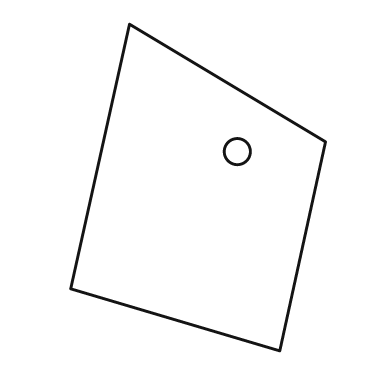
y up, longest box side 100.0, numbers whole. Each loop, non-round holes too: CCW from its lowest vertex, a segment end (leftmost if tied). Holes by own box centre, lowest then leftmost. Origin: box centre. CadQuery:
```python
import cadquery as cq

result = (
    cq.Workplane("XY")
    .moveTo(25.0, -50.0)
    .lineTo(39.0, 14.0)
    .lineTo(-21.0, 50.0)
    .lineTo(-39.0, -31.0)
    .close()
    .moveTo(12.0, 11.0)
    .circle(4.0)
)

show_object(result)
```